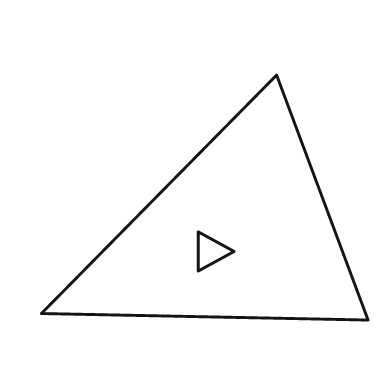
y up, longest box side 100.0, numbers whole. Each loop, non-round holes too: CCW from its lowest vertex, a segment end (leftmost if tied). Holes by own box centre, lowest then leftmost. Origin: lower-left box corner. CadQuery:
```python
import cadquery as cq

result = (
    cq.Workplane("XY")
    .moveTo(100.0, 0.0)
    .lineTo(72.0, 75.0)
    .lineTo(0.0, 2.0)
    .close()
    .moveTo(48.0, 15.0)
    .lineTo(59.0, 21.0)
    .lineTo(48.0, 27.0)
    .close()
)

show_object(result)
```